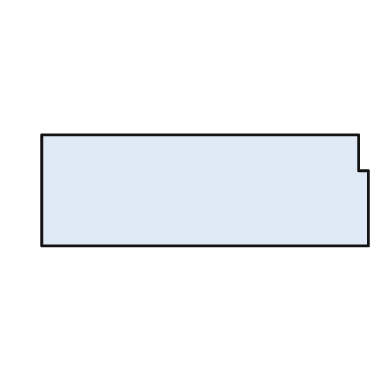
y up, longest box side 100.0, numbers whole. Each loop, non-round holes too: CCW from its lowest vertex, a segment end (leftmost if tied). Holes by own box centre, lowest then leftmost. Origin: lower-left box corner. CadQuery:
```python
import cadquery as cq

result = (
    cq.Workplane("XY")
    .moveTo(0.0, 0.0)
    .lineTo(100.0, 0.0)
    .lineTo(100.0, 23.0)
    .lineTo(97.0, 23.0)
    .lineTo(97.0, 34.0)
    .lineTo(0.0, 34.0)
    .close()
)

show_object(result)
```